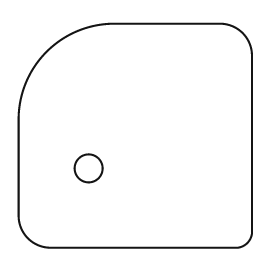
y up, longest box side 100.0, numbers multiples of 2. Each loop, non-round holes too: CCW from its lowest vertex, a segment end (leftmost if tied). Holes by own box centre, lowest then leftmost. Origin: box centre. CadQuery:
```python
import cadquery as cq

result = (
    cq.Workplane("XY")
    .moveTo(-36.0, -48.0)
    .lineTo(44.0, -48.0)
    .threePointArc((48.0, -46.0), (50.0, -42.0))
    .lineTo(50.0, 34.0)
    .threePointArc((46.0, 44.0), (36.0, 48.0))
    .lineTo(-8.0, 48.0)
    .threePointArc((-38.0, 36.0), (-50.0, 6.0))
    .lineTo(-50.0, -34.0)
    .threePointArc((-46.0, -44.0), (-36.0, -48.0))
    .close()
    .moveTo(-20.0, -14.0)
    .circle(6.0)
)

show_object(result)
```